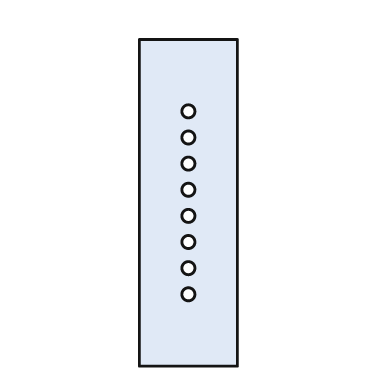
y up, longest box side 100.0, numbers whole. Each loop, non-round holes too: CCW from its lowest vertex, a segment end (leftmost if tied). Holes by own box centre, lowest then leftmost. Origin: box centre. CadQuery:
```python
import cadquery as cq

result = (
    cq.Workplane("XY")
    .moveTo(-15.0, -50.0)
    .lineTo(15.0, -50.0)
    .lineTo(15.0, 50.0)
    .lineTo(-15.0, 50.0)
    .close()
    .moveTo(0.0, -28.0)
    .circle(2.0)
    .moveTo(0.0, -20.0)
    .circle(2.0)
    .moveTo(0.0, -12.0)
    .circle(2.0)
    .moveTo(0.0, -4.0)
    .circle(2.0)
    .moveTo(0.0, 4.0)
    .circle(2.0)
    .moveTo(0.0, 12.0)
    .circle(2.0)
    .moveTo(0.0, 20.0)
    .circle(2.0)
    .moveTo(0.0, 28.0)
    .circle(2.0)
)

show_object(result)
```